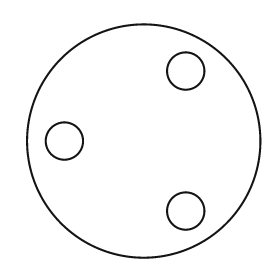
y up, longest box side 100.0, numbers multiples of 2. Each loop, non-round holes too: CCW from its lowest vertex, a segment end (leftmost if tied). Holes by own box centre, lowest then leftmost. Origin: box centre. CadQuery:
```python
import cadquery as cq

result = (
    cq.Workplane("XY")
    .moveTo(0.0, 0.0)
    .circle(50.0)
    .moveTo(18.0, -30.0)
    .circle(8.0)
    .moveTo(-34.0, 0.0)
    .circle(8.0)
    .moveTo(18.0, 30.0)
    .circle(8.0)
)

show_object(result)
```